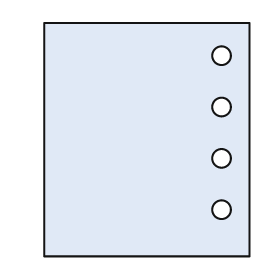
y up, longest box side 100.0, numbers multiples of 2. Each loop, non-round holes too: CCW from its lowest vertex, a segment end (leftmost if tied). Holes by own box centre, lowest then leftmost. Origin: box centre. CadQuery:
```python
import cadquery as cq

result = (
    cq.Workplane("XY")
    .moveTo(-44.0, -50.0)
    .lineTo(44.0, -50.0)
    .lineTo(44.0, 50.0)
    .lineTo(-44.0, 50.0)
    .close()
    .moveTo(32.0, -30.0)
    .circle(4.0)
    .moveTo(32.0, -8.0)
    .circle(4.0)
    .moveTo(32.0, 14.0)
    .circle(4.0)
    .moveTo(32.0, 36.0)
    .circle(4.0)
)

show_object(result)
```